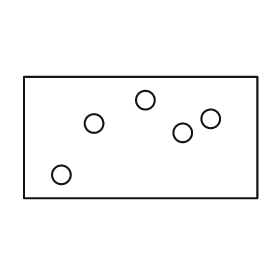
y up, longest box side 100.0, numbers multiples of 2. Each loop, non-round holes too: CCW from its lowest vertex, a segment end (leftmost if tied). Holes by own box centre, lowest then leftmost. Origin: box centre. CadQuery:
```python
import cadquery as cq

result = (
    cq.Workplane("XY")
    .moveTo(-50.0, -26.0)
    .lineTo(50.0, -26.0)
    .lineTo(50.0, 26.0)
    .lineTo(-50.0, 26.0)
    .close()
    .moveTo(-34.0, -16.0)
    .circle(4.0)
    .moveTo(18.0, 2.0)
    .circle(4.0)
    .moveTo(-20.0, 6.0)
    .circle(4.0)
    .moveTo(30.0, 8.0)
    .circle(4.0)
    .moveTo(2.0, 16.0)
    .circle(4.0)
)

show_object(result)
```